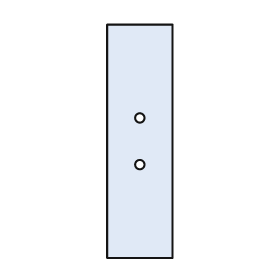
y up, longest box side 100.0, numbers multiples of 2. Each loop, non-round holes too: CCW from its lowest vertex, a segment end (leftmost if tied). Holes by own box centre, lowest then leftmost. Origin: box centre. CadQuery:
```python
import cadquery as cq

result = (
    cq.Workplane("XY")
    .moveTo(-14.0, -50.0)
    .lineTo(14.0, -50.0)
    .lineTo(14.0, 50.0)
    .lineTo(-14.0, 50.0)
    .close()
    .moveTo(0.0, -10.0)
    .circle(2.0)
    .moveTo(0.0, 10.0)
    .circle(2.0)
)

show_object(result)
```